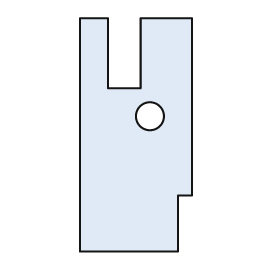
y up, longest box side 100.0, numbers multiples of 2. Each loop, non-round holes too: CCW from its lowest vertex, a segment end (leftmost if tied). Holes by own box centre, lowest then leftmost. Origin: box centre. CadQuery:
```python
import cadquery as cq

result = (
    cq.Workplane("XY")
    .moveTo(-24.0, -50.0)
    .lineTo(18.0, -50.0)
    .lineTo(18.0, -26.0)
    .lineTo(24.0, -26.0)
    .lineTo(24.0, 50.0)
    .lineTo(2.0, 50.0)
    .lineTo(2.0, 20.0)
    .lineTo(-12.0, 20.0)
    .lineTo(-12.0, 50.0)
    .lineTo(-24.0, 50.0)
    .close()
    .moveTo(6.0, 8.0)
    .circle(6.0)
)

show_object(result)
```